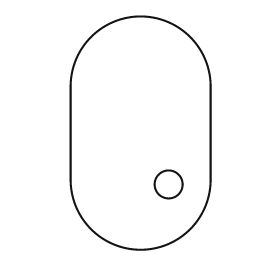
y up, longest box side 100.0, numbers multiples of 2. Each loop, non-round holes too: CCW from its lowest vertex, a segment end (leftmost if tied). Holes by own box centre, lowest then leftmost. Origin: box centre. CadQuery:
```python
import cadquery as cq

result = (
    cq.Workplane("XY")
    .moveTo(-30.0, -20.0)
    .threePointArc((0.0, -50.0), (30.0, -20.0))
    .lineTo(30.0, 20.0)
    .threePointArc((0.0, 50.0), (-30.0, 20.0))
    .close()
    .moveTo(12.0, -22.0)
    .circle(6.0)
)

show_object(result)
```